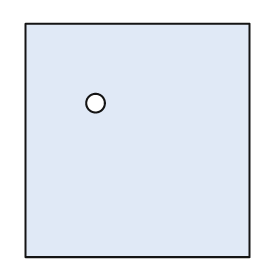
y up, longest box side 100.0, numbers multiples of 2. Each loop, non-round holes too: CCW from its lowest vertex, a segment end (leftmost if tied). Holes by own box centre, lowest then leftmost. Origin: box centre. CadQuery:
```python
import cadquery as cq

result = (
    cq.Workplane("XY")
    .moveTo(-48.0, -50.0)
    .lineTo(48.0, -50.0)
    .lineTo(48.0, 50.0)
    .lineTo(-48.0, 50.0)
    .close()
    .moveTo(-18.0, 16.0)
    .circle(4.0)
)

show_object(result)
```